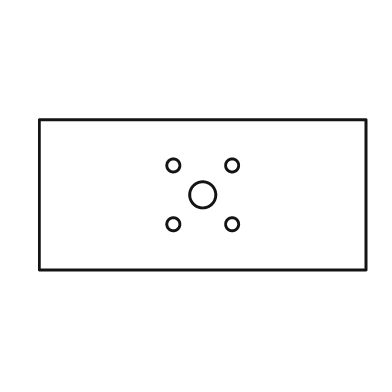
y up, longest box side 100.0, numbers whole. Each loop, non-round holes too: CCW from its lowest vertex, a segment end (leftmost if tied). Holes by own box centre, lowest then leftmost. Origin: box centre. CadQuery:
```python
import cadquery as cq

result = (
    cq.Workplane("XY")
    .moveTo(-50.0, -23.0)
    .lineTo(50.0, -23.0)
    .lineTo(50.0, 23.0)
    .lineTo(-50.0, 23.0)
    .close()
    .moveTo(-9.0, -9.0)
    .circle(2.0)
    .moveTo(9.0, -9.0)
    .circle(2.0)
    .moveTo(0.0, 0.0)
    .circle(4.0)
    .moveTo(-9.0, 9.0)
    .circle(2.0)
    .moveTo(9.0, 9.0)
    .circle(2.0)
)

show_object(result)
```